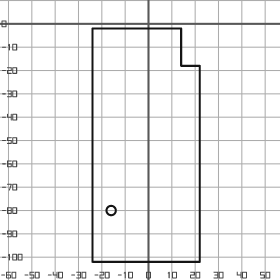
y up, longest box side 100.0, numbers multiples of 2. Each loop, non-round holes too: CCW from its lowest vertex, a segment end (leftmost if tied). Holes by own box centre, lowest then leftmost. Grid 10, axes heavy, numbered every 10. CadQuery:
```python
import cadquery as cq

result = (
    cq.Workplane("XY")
    .moveTo(-24.0, -102.0)
    .lineTo(22.0, -102.0)
    .lineTo(22.0, -18.0)
    .lineTo(14.0, -18.0)
    .lineTo(14.0, -2.0)
    .lineTo(-24.0, -2.0)
    .close()
    .moveTo(-16.0, -80.0)
    .circle(2.0)
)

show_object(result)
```